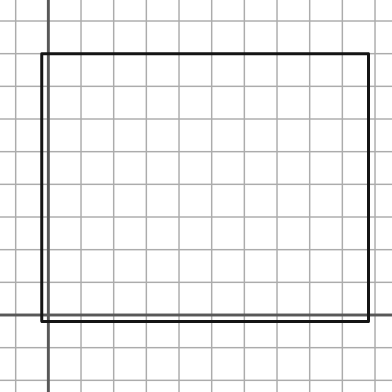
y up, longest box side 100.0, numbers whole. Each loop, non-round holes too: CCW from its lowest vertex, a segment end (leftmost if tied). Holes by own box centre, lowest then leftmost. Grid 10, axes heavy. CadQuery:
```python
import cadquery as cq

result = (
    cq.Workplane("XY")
    .moveTo(-2.0, -2.0)
    .lineTo(98.0, -2.0)
    .lineTo(98.0, 80.0)
    .lineTo(-2.0, 80.0)
    .close()
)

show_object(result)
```